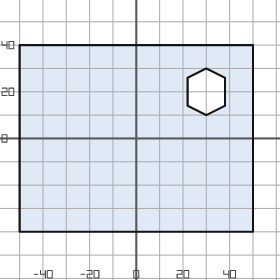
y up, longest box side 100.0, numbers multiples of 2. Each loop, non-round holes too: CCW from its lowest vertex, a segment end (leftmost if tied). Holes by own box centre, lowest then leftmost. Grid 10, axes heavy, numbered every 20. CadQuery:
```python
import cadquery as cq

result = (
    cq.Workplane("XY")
    .moveTo(-50.0, -40.0)
    .lineTo(50.0, -40.0)
    .lineTo(50.0, 40.0)
    .lineTo(-50.0, 40.0)
    .close()
    .moveTo(30.0, 10.0)
    .lineTo(38.0, 14.0)
    .lineTo(38.0, 26.0)
    .lineTo(30.0, 30.0)
    .lineTo(22.0, 26.0)
    .lineTo(22.0, 14.0)
    .close()
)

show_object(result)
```